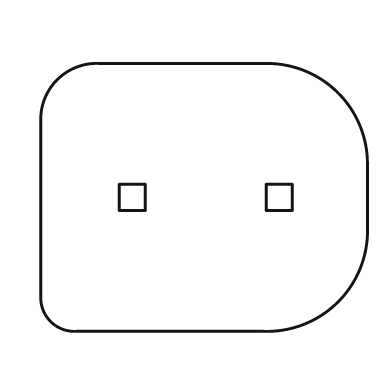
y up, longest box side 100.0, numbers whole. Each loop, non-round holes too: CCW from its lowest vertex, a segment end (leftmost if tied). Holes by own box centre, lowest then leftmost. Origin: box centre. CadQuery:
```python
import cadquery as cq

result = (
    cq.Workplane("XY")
    .moveTo(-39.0, -41.0)
    .lineTo(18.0, -41.0)
    .threePointArc((41.0, -32.0), (50.0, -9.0))
    .lineTo(50.0, 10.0)
    .threePointArc((41.0, 32.0), (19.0, 41.0))
    .lineTo(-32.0, 41.0)
    .threePointArc((-45.0, 36.0), (-50.0, 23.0))
    .lineTo(-50.0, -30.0)
    .threePointArc((-47.0, -38.0), (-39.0, -41.0))
    .close()
    .moveTo(-26.0, -4.0)
    .lineTo(-18.0, -4.0)
    .lineTo(-18.0, 4.0)
    .lineTo(-26.0, 4.0)
    .close()
    .moveTo(19.0, -4.0)
    .lineTo(27.0, -4.0)
    .lineTo(27.0, 4.0)
    .lineTo(19.0, 4.0)
    .close()
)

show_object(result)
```